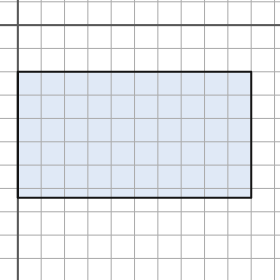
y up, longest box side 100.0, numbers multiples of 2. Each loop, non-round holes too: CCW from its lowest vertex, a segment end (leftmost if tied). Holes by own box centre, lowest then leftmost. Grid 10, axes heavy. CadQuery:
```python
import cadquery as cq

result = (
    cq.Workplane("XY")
    .moveTo(0.0, -74.0)
    .lineTo(100.0, -74.0)
    .lineTo(100.0, -20.0)
    .lineTo(0.0, -20.0)
    .close()
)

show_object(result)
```